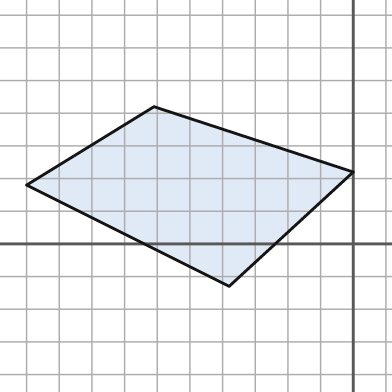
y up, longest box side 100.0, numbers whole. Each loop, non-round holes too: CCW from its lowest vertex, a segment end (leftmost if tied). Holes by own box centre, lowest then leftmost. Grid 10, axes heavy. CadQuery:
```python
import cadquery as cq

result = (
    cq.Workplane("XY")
    .moveTo(-38.0, -13.0)
    .lineTo(0.0, 22.0)
    .lineTo(-61.0, 42.0)
    .lineTo(-100.0, 18.0)
    .close()
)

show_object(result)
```